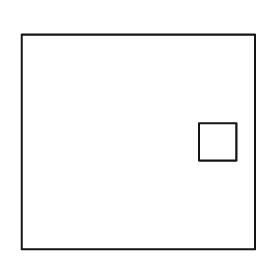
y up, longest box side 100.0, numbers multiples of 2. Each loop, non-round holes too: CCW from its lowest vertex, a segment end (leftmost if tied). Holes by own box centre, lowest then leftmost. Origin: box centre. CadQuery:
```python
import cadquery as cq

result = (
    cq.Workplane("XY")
    .moveTo(-50.0, -46.0)
    .lineTo(50.0, -46.0)
    .lineTo(50.0, 46.0)
    .lineTo(-50.0, 46.0)
    .close()
    .moveTo(26.0, -8.0)
    .lineTo(42.0, -8.0)
    .lineTo(42.0, 8.0)
    .lineTo(26.0, 8.0)
    .close()
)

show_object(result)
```